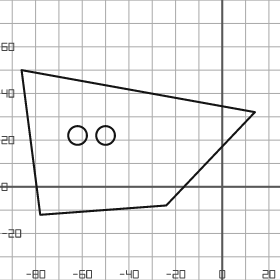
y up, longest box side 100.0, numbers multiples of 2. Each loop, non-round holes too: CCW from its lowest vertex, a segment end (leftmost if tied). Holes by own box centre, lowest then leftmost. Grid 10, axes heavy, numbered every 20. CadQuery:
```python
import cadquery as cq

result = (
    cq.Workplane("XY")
    .moveTo(-78.0, -12.0)
    .lineTo(-24.0, -8.0)
    .lineTo(14.0, 32.0)
    .lineTo(-86.0, 50.0)
    .close()
    .moveTo(-62.0, 22.0)
    .circle(4.0)
    .moveTo(-50.0, 22.0)
    .circle(4.0)
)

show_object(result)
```